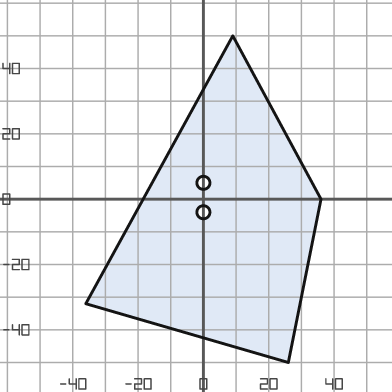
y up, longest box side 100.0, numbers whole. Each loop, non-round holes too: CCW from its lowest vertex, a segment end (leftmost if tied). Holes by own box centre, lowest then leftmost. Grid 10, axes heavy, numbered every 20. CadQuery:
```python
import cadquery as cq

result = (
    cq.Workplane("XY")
    .moveTo(26.0, -50.0)
    .lineTo(36.0, 0.0)
    .lineTo(9.0, 50.0)
    .lineTo(-36.0, -32.0)
    .close()
    .moveTo(0.0, -4.0)
    .circle(2.0)
    .moveTo(0.0, 5.0)
    .circle(2.0)
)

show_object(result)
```